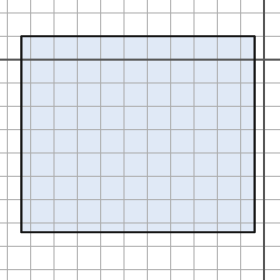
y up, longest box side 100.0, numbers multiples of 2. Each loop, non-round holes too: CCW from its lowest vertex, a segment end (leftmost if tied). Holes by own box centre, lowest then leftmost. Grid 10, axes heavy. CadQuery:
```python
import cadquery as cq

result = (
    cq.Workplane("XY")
    .moveTo(-104.0, -74.0)
    .lineTo(-4.0, -74.0)
    .lineTo(-4.0, 10.0)
    .lineTo(-104.0, 10.0)
    .close()
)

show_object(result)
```